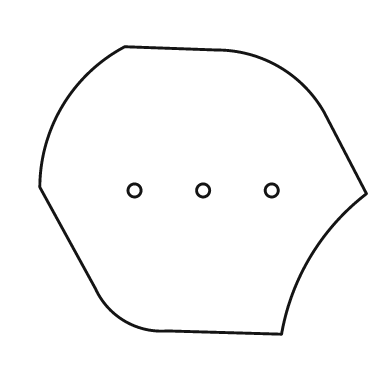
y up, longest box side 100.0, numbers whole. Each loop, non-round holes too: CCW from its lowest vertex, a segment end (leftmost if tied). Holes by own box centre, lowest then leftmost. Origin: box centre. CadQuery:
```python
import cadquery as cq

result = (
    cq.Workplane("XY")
    .moveTo(24.0, -44.0)
    .threePointArc((33.0, -20.0), (50.0, -1.0))
    .lineTo(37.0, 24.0)
    .threePointArc((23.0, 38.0), (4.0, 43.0))
    .lineTo(-24.0, 44.0)
    .threePointArc((-43.0, 26.0), (-50.0, 1.0))
    .lineTo(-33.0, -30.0)
    .threePointArc((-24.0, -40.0), (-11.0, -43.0))
    .close()
    .moveTo(-21.0, 0.0)
    .circle(2.0)
    .moveTo(0.0, 0.0)
    .circle(2.0)
    .moveTo(21.0, 0.0)
    .circle(2.0)
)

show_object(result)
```